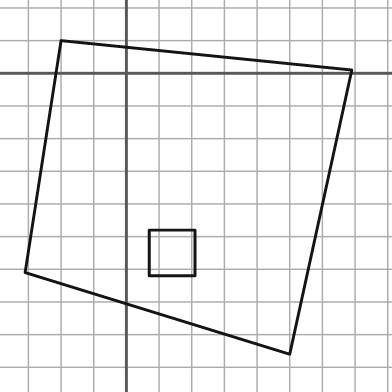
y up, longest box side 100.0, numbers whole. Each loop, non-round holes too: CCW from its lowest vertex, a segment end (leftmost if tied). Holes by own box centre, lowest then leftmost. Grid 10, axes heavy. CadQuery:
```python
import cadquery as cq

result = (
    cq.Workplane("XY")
    .moveTo(50.0, -86.0)
    .lineTo(69.0, 1.0)
    .lineTo(-20.0, 10.0)
    .lineTo(-31.0, -61.0)
    .close()
    .moveTo(7.0, -62.0)
    .lineTo(21.0, -62.0)
    .lineTo(21.0, -48.0)
    .lineTo(7.0, -48.0)
    .close()
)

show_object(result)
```